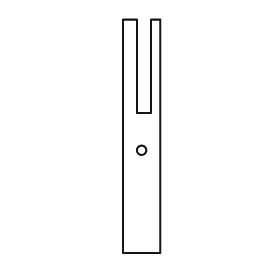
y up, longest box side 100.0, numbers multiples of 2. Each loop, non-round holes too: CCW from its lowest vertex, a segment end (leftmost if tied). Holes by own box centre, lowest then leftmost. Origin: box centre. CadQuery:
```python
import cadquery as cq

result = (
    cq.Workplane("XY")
    .moveTo(-8.0, -50.0)
    .lineTo(8.0, -50.0)
    .lineTo(8.0, 50.0)
    .lineTo(4.0, 50.0)
    .lineTo(4.0, 10.0)
    .lineTo(-2.0, 10.0)
    .lineTo(-2.0, 50.0)
    .lineTo(-8.0, 50.0)
    .close()
    .moveTo(0.0, -6.0)
    .circle(2.0)
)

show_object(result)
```